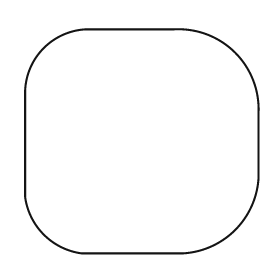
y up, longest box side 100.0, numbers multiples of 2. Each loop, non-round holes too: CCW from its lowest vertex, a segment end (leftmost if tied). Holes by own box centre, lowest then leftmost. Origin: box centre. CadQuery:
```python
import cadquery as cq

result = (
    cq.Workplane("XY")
    .moveTo(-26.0, -48.0)
    .lineTo(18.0, -48.0)
    .threePointArc((40.0, -38.0), (50.0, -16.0))
    .lineTo(50.0, 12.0)
    .threePointArc((40.0, 38.0), (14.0, 48.0))
    .lineTo(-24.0, 48.0)
    .threePointArc((-42.0, 40.0), (-50.0, 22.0))
    .lineTo(-50.0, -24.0)
    .threePointArc((-42.0, -40.0), (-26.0, -48.0))
    .close()
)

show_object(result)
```